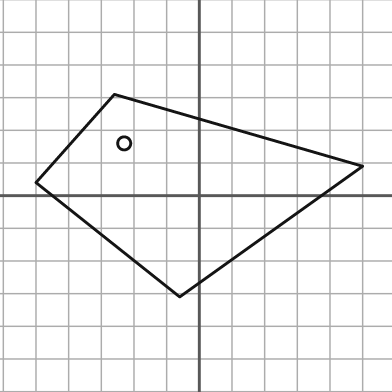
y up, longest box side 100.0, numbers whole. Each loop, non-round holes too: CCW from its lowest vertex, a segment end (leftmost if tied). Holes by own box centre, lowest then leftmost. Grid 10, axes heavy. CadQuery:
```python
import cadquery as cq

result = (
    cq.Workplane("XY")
    .moveTo(-6.0, -31.0)
    .lineTo(50.0, 9.0)
    .lineTo(-26.0, 31.0)
    .lineTo(-50.0, 4.0)
    .close()
    .moveTo(-23.0, 16.0)
    .circle(2.0)
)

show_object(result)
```